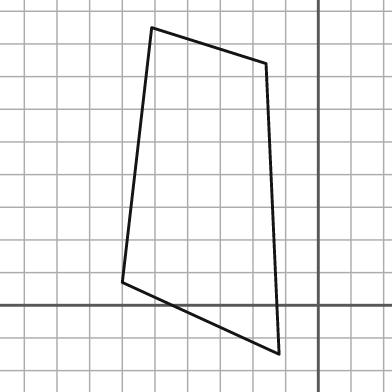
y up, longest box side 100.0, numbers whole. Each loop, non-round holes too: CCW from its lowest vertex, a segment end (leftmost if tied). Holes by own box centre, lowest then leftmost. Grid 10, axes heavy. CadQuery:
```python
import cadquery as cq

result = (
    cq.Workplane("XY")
    .moveTo(-12.0, -15.0)
    .lineTo(-16.0, 74.0)
    .lineTo(-51.0, 85.0)
    .lineTo(-60.0, 7.0)
    .close()
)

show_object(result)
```